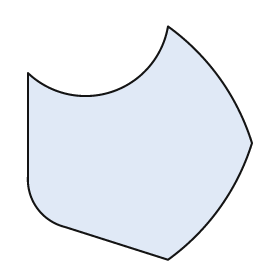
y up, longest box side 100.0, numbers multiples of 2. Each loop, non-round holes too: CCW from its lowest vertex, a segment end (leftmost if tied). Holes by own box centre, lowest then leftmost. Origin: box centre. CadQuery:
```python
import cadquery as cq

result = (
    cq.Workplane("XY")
    .moveTo(12.0, -50.0)
    .threePointArc((34.0, -28.0), (48.0, 0.0))
    .threePointArc((34.0, 28.0), (12.0, 50.0))
    .threePointArc((-12.0, 22.0), (-48.0, 30.0))
    .lineTo(-48.0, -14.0)
    .threePointArc((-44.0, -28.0), (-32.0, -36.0))
    .close()
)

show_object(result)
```